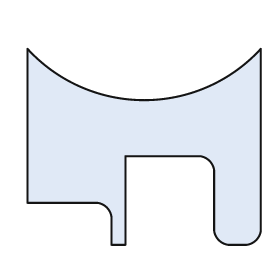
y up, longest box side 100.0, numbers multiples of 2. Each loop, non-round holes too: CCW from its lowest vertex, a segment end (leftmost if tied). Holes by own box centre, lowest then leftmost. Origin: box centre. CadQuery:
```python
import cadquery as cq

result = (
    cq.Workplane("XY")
    .moveTo(-14.0, -42.0)
    .lineTo(-8.0, -42.0)
    .lineTo(-8.0, -4.0)
    .lineTo(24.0, -4.0)
    .threePointArc((28.0, -6.0), (30.0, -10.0))
    .lineTo(30.0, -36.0)
    .threePointArc((32.0, -40.0), (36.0, -42.0))
    .lineTo(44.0, -42.0)
    .threePointArc((48.0, -40.0), (50.0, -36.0))
    .lineTo(50.0, 42.0)
    .threePointArc((0.0, 20.0), (-50.0, 42.0))
    .lineTo(-50.0, -24.0)
    .lineTo(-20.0, -24.0)
    .threePointArc((-16.0, -26.0), (-14.0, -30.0))
    .close()
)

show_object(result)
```